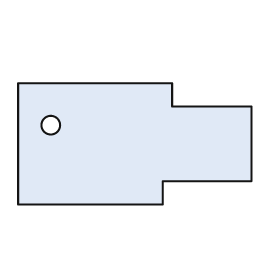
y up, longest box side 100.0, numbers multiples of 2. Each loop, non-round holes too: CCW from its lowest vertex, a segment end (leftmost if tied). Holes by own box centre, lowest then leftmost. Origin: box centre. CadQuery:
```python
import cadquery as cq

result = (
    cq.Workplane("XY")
    .moveTo(-50.0, -26.0)
    .lineTo(12.0, -26.0)
    .lineTo(12.0, -16.0)
    .lineTo(50.0, -16.0)
    .lineTo(50.0, 16.0)
    .lineTo(16.0, 16.0)
    .lineTo(16.0, 26.0)
    .lineTo(-50.0, 26.0)
    .close()
    .moveTo(-36.0, 8.0)
    .circle(4.0)
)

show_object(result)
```